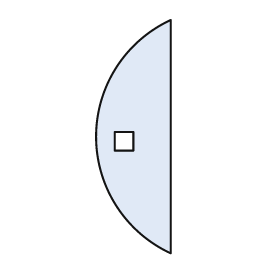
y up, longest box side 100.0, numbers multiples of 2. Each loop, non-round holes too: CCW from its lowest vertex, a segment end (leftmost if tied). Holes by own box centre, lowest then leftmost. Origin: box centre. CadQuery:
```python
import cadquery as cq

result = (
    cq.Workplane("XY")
    .moveTo(16.0, -50.0)
    .lineTo(16.0, 50.0)
    .threePointArc((-16.0, 0.0), (16.0, -50.0))
    .close()
    .moveTo(-8.0, -6.0)
    .lineTo(0.0, -6.0)
    .lineTo(0.0, 2.0)
    .lineTo(-8.0, 2.0)
    .close()
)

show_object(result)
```